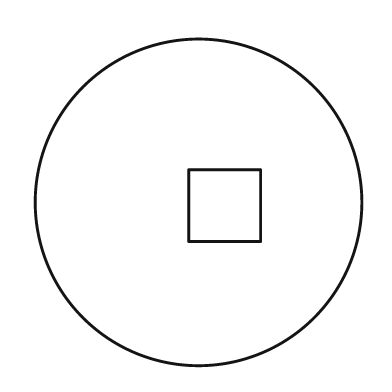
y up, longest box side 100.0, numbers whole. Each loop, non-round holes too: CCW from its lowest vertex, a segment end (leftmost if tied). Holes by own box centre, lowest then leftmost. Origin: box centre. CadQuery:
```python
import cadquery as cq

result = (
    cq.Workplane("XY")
    .moveTo(0.0, 0.0)
    .circle(50.0)
    .moveTo(-3.0, -12.0)
    .lineTo(19.0, -12.0)
    .lineTo(19.0, 10.0)
    .lineTo(-3.0, 10.0)
    .close()
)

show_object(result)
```